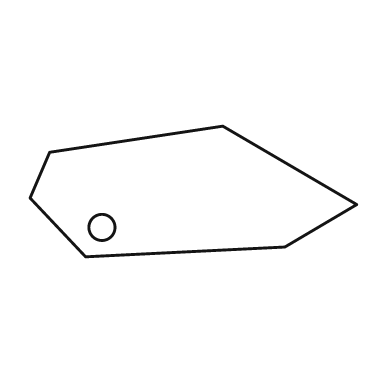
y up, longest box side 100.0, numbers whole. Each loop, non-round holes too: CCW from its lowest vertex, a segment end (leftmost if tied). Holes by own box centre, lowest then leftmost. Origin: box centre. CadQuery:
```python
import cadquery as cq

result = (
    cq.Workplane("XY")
    .moveTo(-33.0, -20.0)
    .lineTo(28.0, -17.0)
    .lineTo(50.0, -4.0)
    .lineTo(9.0, 20.0)
    .lineTo(-44.0, 12.0)
    .lineTo(-50.0, -2.0)
    .close()
    .moveTo(-28.0, -11.0)
    .circle(4.0)
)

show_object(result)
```